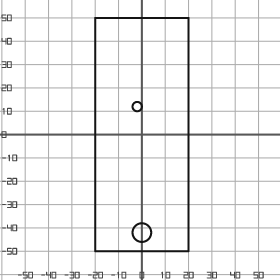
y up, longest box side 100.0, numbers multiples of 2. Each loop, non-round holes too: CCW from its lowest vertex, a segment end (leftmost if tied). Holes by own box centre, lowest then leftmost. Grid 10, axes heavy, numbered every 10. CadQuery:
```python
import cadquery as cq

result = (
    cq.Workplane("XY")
    .moveTo(-20.0, -50.0)
    .lineTo(20.0, -50.0)
    .lineTo(20.0, 50.0)
    .lineTo(-20.0, 50.0)
    .close()
    .moveTo(0.0, -42.0)
    .circle(4.0)
    .moveTo(-2.0, 12.0)
    .circle(2.0)
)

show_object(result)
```